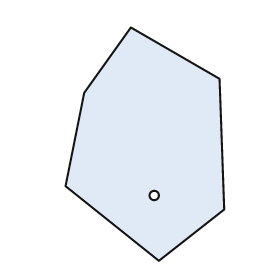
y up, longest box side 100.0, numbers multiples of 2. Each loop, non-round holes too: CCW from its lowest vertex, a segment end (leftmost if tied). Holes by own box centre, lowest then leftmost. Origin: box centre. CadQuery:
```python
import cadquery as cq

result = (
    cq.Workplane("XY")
    .moveTo(6.0, -50.0)
    .lineTo(34.0, -28.0)
    .lineTo(32.0, 28.0)
    .lineTo(-6.0, 50.0)
    .lineTo(-26.0, 22.0)
    .lineTo(-34.0, -18.0)
    .close()
    .moveTo(4.0, -22.0)
    .circle(2.0)
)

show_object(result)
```